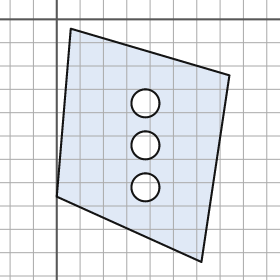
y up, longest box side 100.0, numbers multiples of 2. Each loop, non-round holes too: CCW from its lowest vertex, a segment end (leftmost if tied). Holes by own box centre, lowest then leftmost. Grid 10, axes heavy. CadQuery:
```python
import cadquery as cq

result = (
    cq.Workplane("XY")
    .moveTo(62.0, -104.0)
    .lineTo(74.0, -24.0)
    .lineTo(6.0, -4.0)
    .lineTo(0.0, -76.0)
    .close()
    .moveTo(38.0, -72.0)
    .circle(6.0)
    .moveTo(38.0, -54.0)
    .circle(6.0)
    .moveTo(38.0, -36.0)
    .circle(6.0)
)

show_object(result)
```